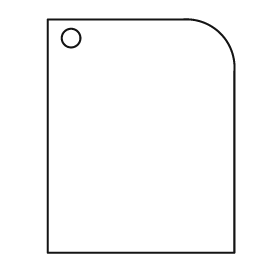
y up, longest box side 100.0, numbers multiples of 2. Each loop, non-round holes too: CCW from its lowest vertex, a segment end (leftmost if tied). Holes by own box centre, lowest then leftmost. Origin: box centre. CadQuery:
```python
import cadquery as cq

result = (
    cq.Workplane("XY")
    .moveTo(-40.0, -50.0)
    .lineTo(40.0, -50.0)
    .lineTo(40.0, 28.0)
    .threePointArc((34.0, 44.0), (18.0, 50.0))
    .lineTo(-40.0, 50.0)
    .close()
    .moveTo(-30.0, 42.0)
    .circle(4.0)
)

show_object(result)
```